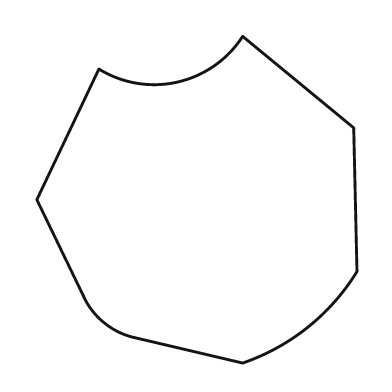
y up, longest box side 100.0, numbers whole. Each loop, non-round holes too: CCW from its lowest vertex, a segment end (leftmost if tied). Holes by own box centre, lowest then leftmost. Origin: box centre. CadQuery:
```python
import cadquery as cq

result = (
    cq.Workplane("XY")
    .moveTo(14.0, -50.0)
    .threePointArc((34.0, -39.0), (49.0, -22.0))
    .lineTo(48.0, 22.0)
    .lineTo(14.0, 50.0)
    .threePointArc((-6.0, 36.0), (-30.0, 40.0))
    .lineTo(-49.0, 0.0)
    .lineTo(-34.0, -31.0)
    .threePointArc((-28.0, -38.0), (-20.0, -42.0))
    .close()
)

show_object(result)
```